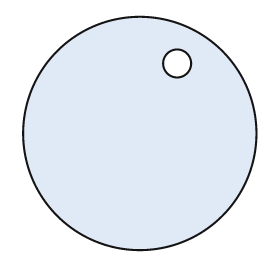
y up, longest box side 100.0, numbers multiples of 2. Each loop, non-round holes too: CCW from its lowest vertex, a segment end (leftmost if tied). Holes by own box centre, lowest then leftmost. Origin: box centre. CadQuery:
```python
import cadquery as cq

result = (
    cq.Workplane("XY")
    .moveTo(0.0, 0.0)
    .circle(50.0)
    .moveTo(16.0, 30.0)
    .circle(6.0)
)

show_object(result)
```